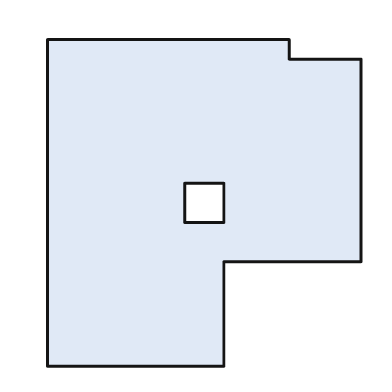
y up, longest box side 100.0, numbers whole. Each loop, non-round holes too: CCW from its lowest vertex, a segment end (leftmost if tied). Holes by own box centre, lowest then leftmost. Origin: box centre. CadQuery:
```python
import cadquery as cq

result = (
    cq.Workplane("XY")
    .moveTo(-48.0, -50.0)
    .lineTo(6.0, -50.0)
    .lineTo(6.0, -18.0)
    .lineTo(48.0, -18.0)
    .lineTo(48.0, 44.0)
    .lineTo(26.0, 44.0)
    .lineTo(26.0, 50.0)
    .lineTo(-48.0, 50.0)
    .close()
    .moveTo(-6.0, -6.0)
    .lineTo(6.0, -6.0)
    .lineTo(6.0, 6.0)
    .lineTo(-6.0, 6.0)
    .close()
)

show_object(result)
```